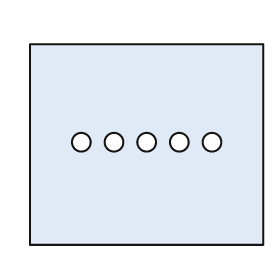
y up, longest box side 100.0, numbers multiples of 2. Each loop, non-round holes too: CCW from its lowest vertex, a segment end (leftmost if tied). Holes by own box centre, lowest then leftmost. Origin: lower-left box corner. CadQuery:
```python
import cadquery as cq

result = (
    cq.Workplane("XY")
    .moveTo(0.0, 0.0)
    .lineTo(100.0, 0.0)
    .lineTo(100.0, 86.0)
    .lineTo(0.0, 86.0)
    .close()
    .moveTo(22.0, 44.0)
    .circle(4.0)
    .moveTo(36.0, 44.0)
    .circle(4.0)
    .moveTo(50.0, 44.0)
    .circle(4.0)
    .moveTo(64.0, 44.0)
    .circle(4.0)
    .moveTo(78.0, 44.0)
    .circle(4.0)
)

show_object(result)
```